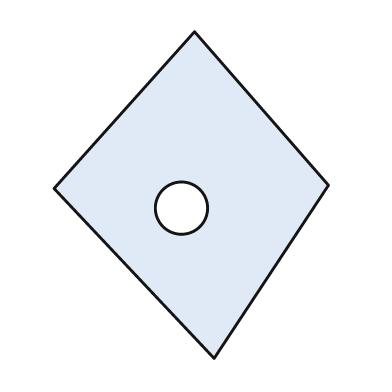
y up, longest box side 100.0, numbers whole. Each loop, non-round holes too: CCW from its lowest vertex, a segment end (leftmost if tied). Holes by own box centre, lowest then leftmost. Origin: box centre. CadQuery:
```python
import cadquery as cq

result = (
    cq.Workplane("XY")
    .moveTo(7.0, -50.0)
    .lineTo(42.0, 3.0)
    .lineTo(1.0, 50.0)
    .lineTo(-42.0, 2.0)
    .close()
    .moveTo(-3.0, -4.0)
    .circle(8.0)
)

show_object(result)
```